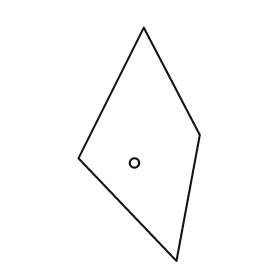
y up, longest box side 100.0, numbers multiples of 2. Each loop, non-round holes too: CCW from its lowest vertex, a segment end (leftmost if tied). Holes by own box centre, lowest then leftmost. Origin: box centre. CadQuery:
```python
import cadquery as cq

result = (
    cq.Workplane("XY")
    .moveTo(16.0, -50.0)
    .lineTo(26.0, 4.0)
    .lineTo(2.0, 50.0)
    .lineTo(-26.0, -6.0)
    .close()
    .moveTo(-2.0, -8.0)
    .circle(2.0)
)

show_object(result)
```